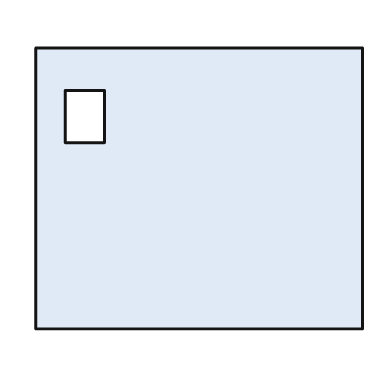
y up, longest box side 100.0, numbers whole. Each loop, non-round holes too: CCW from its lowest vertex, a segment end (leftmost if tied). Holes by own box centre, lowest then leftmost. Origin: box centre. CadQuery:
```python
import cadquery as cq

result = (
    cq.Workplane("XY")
    .moveTo(-50.0, -43.0)
    .lineTo(50.0, -43.0)
    .lineTo(50.0, 43.0)
    .lineTo(-50.0, 43.0)
    .close()
    .moveTo(-41.0, 14.0)
    .lineTo(-29.0, 14.0)
    .lineTo(-29.0, 30.0)
    .lineTo(-41.0, 30.0)
    .close()
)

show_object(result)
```